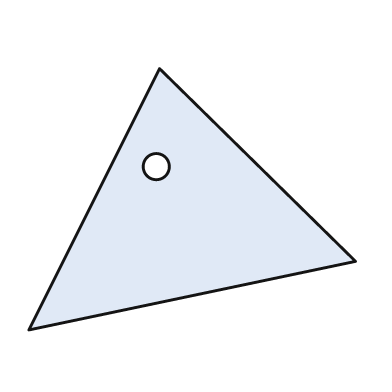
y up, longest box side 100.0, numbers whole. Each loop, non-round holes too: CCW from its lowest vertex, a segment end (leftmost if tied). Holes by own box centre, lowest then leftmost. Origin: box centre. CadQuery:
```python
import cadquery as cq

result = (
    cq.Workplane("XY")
    .moveTo(-50.0, -40.0)
    .lineTo(50.0, -19.0)
    .lineTo(-10.0, 40.0)
    .close()
    .moveTo(-11.0, 10.0)
    .circle(4.0)
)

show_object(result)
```